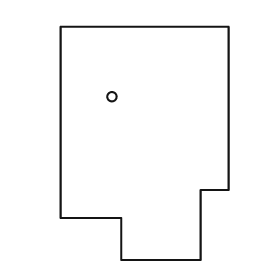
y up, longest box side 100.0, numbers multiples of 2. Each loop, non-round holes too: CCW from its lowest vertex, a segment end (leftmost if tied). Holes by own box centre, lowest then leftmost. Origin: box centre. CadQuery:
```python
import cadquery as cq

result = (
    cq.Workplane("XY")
    .moveTo(-10.0, -50.0)
    .lineTo(24.0, -50.0)
    .lineTo(24.0, -20.0)
    .lineTo(36.0, -20.0)
    .lineTo(36.0, 50.0)
    .lineTo(-36.0, 50.0)
    .lineTo(-36.0, -32.0)
    .lineTo(-10.0, -32.0)
    .close()
    .moveTo(-14.0, 20.0)
    .circle(2.0)
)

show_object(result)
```